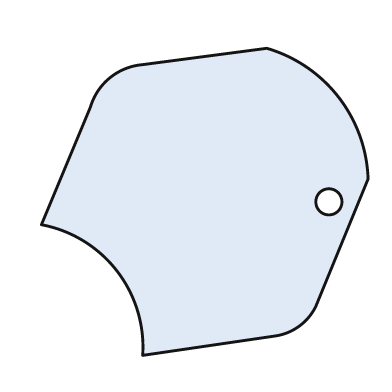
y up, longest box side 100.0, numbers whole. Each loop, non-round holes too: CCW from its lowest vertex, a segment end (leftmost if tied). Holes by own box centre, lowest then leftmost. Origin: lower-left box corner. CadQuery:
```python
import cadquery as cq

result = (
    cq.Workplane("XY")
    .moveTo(31.0, 0.0)
    .lineTo(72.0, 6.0)
    .threePointArc((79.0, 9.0), (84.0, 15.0))
    .lineTo(100.0, 54.0)
    .threePointArc((91.0, 79.0), (69.0, 94.0))
    .lineTo(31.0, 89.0)
    .threePointArc((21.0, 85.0), (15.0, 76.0))
    .lineTo(0.0, 40.0)
    .threePointArc((23.0, 26.0), (31.0, 0.0))
    .close()
    .moveTo(88.0, 47.0)
    .circle(4.0)
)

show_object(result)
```